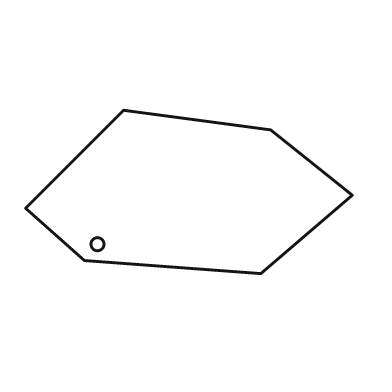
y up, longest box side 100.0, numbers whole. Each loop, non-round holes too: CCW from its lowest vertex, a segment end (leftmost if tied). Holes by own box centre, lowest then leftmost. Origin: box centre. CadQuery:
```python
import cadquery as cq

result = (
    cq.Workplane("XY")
    .moveTo(22.0, -25.0)
    .lineTo(50.0, -1.0)
    .lineTo(25.0, 19.0)
    .lineTo(-20.0, 25.0)
    .lineTo(-50.0, -5.0)
    .lineTo(-32.0, -21.0)
    .close()
    .moveTo(-28.0, -16.0)
    .circle(2.0)
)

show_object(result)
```